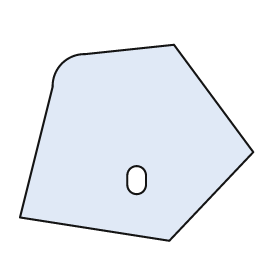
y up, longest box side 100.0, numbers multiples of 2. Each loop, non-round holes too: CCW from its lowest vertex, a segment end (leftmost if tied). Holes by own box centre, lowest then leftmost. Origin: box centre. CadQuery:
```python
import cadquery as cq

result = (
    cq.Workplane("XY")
    .moveTo(14.0, -42.0)
    .lineTo(50.0, -4.0)
    .lineTo(16.0, 42.0)
    .lineTo(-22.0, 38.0)
    .threePointArc((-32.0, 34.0), (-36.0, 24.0))
    .lineTo(-50.0, -32.0)
    .close()
    .moveTo(-4.0, -18.0)
    .threePointArc((0.0, -22.0), (4.0, -18.0))
    .lineTo(4.0, -14.0)
    .threePointArc((0.0, -10.0), (-4.0, -14.0))
    .close()
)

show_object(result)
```